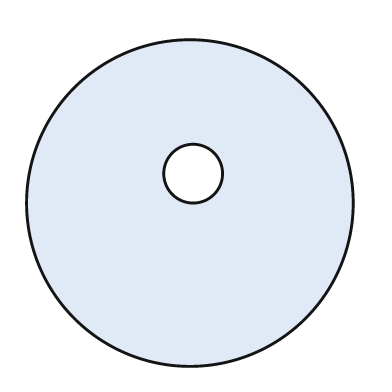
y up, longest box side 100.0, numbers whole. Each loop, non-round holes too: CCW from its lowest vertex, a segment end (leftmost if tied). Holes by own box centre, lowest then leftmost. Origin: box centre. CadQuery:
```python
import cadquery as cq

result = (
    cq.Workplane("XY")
    .moveTo(0.0, 0.0)
    .circle(50.0)
    .moveTo(1.0, 9.0)
    .circle(9.0)
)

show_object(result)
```